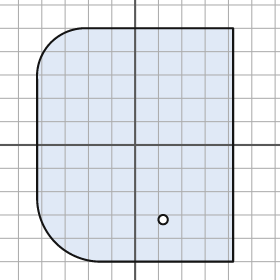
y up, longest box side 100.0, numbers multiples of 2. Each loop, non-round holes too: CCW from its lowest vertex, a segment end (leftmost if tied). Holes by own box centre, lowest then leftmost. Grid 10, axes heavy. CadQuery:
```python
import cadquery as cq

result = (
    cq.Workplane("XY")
    .moveTo(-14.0, -50.0)
    .lineTo(42.0, -50.0)
    .lineTo(42.0, 50.0)
    .lineTo(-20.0, 50.0)
    .threePointArc((-36.0, 44.0), (-42.0, 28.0))
    .lineTo(-42.0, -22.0)
    .threePointArc((-34.0, -42.0), (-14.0, -50.0))
    .close()
    .moveTo(12.0, -32.0)
    .circle(2.0)
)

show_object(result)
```